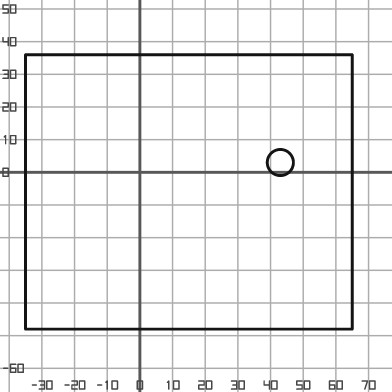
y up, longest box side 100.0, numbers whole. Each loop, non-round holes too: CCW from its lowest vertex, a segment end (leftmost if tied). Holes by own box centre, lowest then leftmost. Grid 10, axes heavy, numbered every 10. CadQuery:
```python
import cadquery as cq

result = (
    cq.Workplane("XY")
    .moveTo(-35.0, -48.0)
    .lineTo(65.0, -48.0)
    .lineTo(65.0, 36.0)
    .lineTo(-35.0, 36.0)
    .close()
    .moveTo(43.0, 3.0)
    .circle(4.0)
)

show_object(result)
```